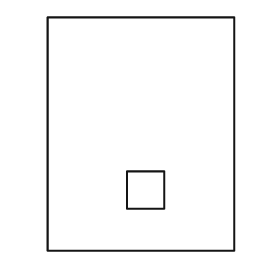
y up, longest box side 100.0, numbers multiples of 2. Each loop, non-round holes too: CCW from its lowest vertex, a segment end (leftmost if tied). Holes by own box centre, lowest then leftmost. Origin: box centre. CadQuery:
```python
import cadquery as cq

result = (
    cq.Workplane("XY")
    .moveTo(-40.0, -50.0)
    .lineTo(40.0, -50.0)
    .lineTo(40.0, 50.0)
    .lineTo(-40.0, 50.0)
    .close()
    .moveTo(-6.0, -32.0)
    .lineTo(10.0, -32.0)
    .lineTo(10.0, -16.0)
    .lineTo(-6.0, -16.0)
    .close()
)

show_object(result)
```